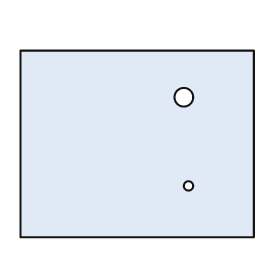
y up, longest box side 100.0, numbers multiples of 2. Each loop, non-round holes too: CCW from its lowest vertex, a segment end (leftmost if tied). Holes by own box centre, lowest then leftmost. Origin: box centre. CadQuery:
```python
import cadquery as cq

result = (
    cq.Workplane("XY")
    .moveTo(-50.0, -40.0)
    .lineTo(50.0, -40.0)
    .lineTo(50.0, 40.0)
    .lineTo(-50.0, 40.0)
    .close()
    .moveTo(22.0, -18.0)
    .circle(2.0)
    .moveTo(20.0, 20.0)
    .circle(4.0)
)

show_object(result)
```